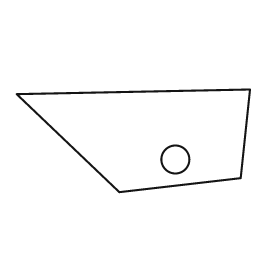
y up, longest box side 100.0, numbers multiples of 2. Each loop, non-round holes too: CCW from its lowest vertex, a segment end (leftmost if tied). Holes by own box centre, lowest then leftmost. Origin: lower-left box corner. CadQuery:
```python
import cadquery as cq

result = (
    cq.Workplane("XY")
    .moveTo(44.0, 0.0)
    .lineTo(96.0, 6.0)
    .lineTo(100.0, 44.0)
    .lineTo(0.0, 42.0)
    .close()
    .moveTo(68.0, 14.0)
    .circle(6.0)
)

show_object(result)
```